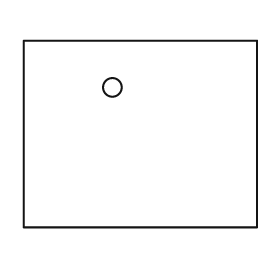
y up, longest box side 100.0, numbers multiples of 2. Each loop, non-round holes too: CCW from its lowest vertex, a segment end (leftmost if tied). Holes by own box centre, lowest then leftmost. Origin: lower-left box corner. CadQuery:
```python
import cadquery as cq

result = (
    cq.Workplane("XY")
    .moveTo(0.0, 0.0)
    .lineTo(100.0, 0.0)
    .lineTo(100.0, 80.0)
    .lineTo(0.0, 80.0)
    .close()
    .moveTo(38.0, 60.0)
    .circle(4.0)
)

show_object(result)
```